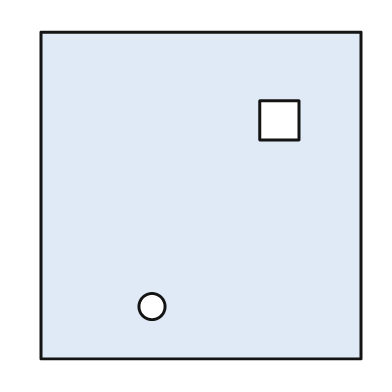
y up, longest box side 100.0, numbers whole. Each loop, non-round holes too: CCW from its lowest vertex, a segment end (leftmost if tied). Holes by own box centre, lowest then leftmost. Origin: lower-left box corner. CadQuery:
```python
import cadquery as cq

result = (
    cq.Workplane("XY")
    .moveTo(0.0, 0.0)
    .lineTo(98.0, 0.0)
    .lineTo(98.0, 100.0)
    .lineTo(0.0, 100.0)
    .close()
    .moveTo(34.0, 16.0)
    .circle(4.0)
    .moveTo(67.0, 67.0)
    .lineTo(79.0, 67.0)
    .lineTo(79.0, 79.0)
    .lineTo(67.0, 79.0)
    .close()
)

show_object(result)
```